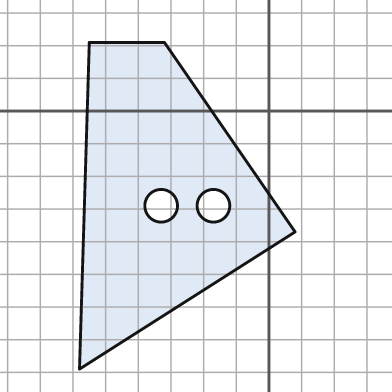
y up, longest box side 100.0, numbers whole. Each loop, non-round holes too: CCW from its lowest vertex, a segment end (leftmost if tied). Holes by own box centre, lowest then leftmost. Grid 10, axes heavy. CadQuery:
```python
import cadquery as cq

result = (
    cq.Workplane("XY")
    .moveTo(-58.0, -79.0)
    .lineTo(8.0, -37.0)
    .lineTo(-32.0, 21.0)
    .lineTo(-55.0, 21.0)
    .close()
    .moveTo(-33.0, -29.0)
    .circle(5.0)
    .moveTo(-17.0, -29.0)
    .circle(5.0)
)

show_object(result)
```